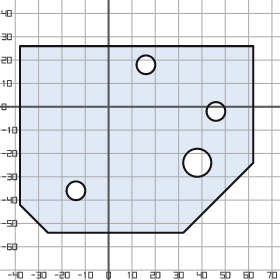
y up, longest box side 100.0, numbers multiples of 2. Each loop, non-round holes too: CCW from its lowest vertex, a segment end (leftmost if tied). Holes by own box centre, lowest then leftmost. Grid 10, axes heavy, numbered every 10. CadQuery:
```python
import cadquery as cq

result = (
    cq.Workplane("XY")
    .moveTo(-26.0, -54.0)
    .lineTo(32.0, -54.0)
    .lineTo(62.0, -24.0)
    .lineTo(62.0, 26.0)
    .lineTo(-38.0, 26.0)
    .lineTo(-38.0, -42.0)
    .close()
    .moveTo(-14.0, -36.0)
    .circle(4.0)
    .moveTo(38.0, -24.0)
    .circle(6.0)
    .moveTo(46.0, -2.0)
    .circle(4.0)
    .moveTo(16.0, 18.0)
    .circle(4.0)
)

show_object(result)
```